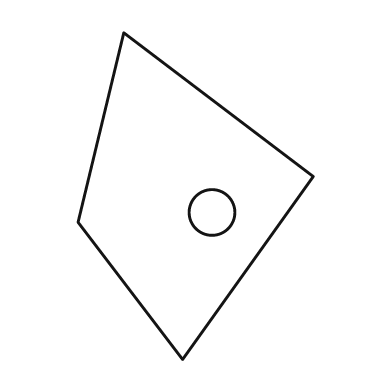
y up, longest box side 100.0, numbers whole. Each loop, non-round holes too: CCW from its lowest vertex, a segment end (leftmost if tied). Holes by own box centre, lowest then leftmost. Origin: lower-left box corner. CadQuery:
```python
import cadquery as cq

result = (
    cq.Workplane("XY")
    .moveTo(32.0, 0.0)
    .lineTo(72.0, 56.0)
    .lineTo(14.0, 100.0)
    .lineTo(0.0, 42.0)
    .close()
    .moveTo(41.0, 45.0)
    .circle(7.0)
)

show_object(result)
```